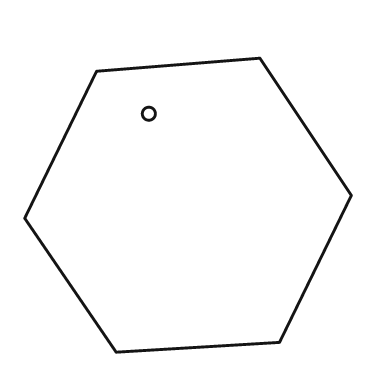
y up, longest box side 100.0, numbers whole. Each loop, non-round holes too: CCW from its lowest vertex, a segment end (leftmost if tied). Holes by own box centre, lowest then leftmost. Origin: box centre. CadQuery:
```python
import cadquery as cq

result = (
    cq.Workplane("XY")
    .moveTo(-22.0, -45.0)
    .lineTo(28.0, -42.0)
    .lineTo(50.0, 3.0)
    .lineTo(22.0, 45.0)
    .lineTo(-28.0, 41.0)
    .lineTo(-50.0, -4.0)
    .close()
    .moveTo(-12.0, 28.0)
    .circle(2.0)
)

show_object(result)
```